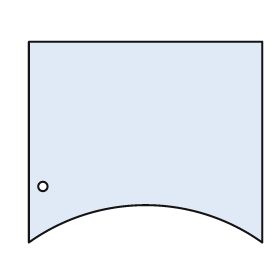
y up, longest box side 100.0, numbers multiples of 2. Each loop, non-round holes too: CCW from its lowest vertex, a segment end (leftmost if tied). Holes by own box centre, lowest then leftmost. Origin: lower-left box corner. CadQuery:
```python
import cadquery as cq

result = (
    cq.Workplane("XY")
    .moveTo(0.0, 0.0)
    .threePointArc((50.0, 16.0), (100.0, 0.0))
    .lineTo(100.0, 86.0)
    .lineTo(0.0, 86.0)
    .close()
    .moveTo(6.0, 24.0)
    .circle(2.0)
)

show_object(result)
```